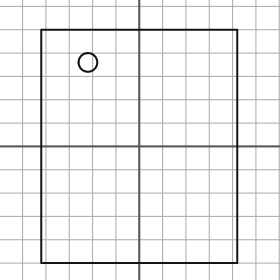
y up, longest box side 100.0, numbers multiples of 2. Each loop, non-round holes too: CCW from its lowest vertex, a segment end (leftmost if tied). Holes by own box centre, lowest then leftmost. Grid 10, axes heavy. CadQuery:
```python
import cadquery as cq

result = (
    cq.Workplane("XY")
    .moveTo(-42.0, -50.0)
    .lineTo(42.0, -50.0)
    .lineTo(42.0, 50.0)
    .lineTo(-42.0, 50.0)
    .close()
    .moveTo(-22.0, 36.0)
    .circle(4.0)
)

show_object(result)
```